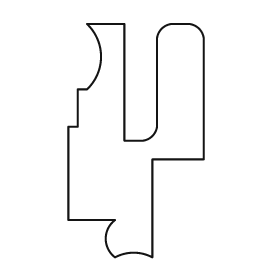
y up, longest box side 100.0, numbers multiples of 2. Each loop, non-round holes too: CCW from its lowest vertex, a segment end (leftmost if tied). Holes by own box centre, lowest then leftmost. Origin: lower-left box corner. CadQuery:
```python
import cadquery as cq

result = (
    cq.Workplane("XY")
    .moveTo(20.0, 0.0)
    .threePointArc((28.0, 2.0), (36.0, 0.0))
    .lineTo(36.0, 42.0)
    .lineTo(58.0, 42.0)
    .lineTo(58.0, 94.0)
    .threePointArc((56.0, 98.0), (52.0, 100.0))
    .lineTo(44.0, 100.0)
    .threePointArc((40.0, 98.0), (38.0, 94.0))
    .lineTo(38.0, 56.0)
    .threePointArc((36.0, 52.0), (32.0, 50.0))
    .lineTo(24.0, 50.0)
    .lineTo(24.0, 100.0)
    .lineTo(8.0, 100.0)
    .threePointArc((14.0, 86.0), (8.0, 72.0))
    .lineTo(4.0, 72.0)
    .lineTo(4.0, 56.0)
    .lineTo(0.0, 56.0)
    .lineTo(0.0, 16.0)
    .lineTo(20.0, 16.0)
    .threePointArc((16.0, 8.0), (20.0, 0.0))
    .close()
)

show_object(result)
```